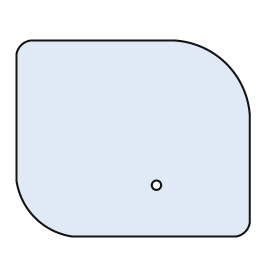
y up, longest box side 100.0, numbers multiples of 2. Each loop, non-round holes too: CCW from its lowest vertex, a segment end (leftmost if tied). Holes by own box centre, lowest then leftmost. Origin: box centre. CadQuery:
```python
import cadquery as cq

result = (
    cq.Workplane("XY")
    .moveTo(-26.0, -42.0)
    .lineTo(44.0, -42.0)
    .threePointArc((48.0, -40.0), (50.0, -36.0))
    .lineTo(50.0, 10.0)
    .threePointArc((40.0, 32.0), (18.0, 42.0))
    .lineTo(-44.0, 42.0)
    .threePointArc((-48.0, 40.0), (-50.0, 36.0))
    .lineTo(-50.0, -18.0)
    .threePointArc((-42.0, -34.0), (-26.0, -42.0))
    .close()
    .moveTo(10.0, -20.0)
    .circle(2.0)
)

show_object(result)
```